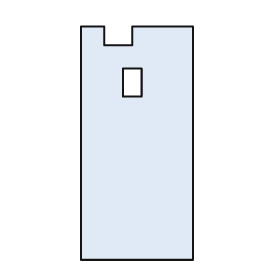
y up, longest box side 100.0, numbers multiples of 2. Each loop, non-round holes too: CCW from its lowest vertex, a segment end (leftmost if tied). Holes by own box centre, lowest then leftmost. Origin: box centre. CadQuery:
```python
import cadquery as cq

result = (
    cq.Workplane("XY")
    .moveTo(-24.0, -50.0)
    .lineTo(24.0, -50.0)
    .lineTo(24.0, 50.0)
    .lineTo(-2.0, 50.0)
    .lineTo(-2.0, 42.0)
    .lineTo(-14.0, 42.0)
    .lineTo(-14.0, 50.0)
    .lineTo(-24.0, 50.0)
    .close()
    .moveTo(-6.0, 20.0)
    .lineTo(2.0, 20.0)
    .lineTo(2.0, 32.0)
    .lineTo(-6.0, 32.0)
    .close()
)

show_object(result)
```